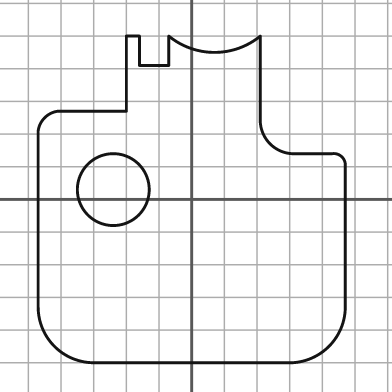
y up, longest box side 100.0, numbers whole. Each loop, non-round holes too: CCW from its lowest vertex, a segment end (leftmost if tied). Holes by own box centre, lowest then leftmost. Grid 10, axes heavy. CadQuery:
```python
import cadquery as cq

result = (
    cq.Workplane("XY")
    .moveTo(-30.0, -50.0)
    .lineTo(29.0, -50.0)
    .threePointArc((42.0, -45.0), (47.0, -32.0))
    .lineTo(47.0, 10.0)
    .threePointArc((46.0, 13.0), (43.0, 14.0))
    .lineTo(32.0, 14.0)
    .threePointArc((24.0, 17.0), (21.0, 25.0))
    .lineTo(21.0, 50.0)
    .threePointArc((7.0, 45.0), (-7.0, 50.0))
    .lineTo(-7.0, 41.0)
    .lineTo(-16.0, 41.0)
    .lineTo(-16.0, 50.0)
    .lineTo(-20.0, 50.0)
    .lineTo(-20.0, 27.0)
    .lineTo(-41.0, 27.0)
    .threePointArc((-45.0, 25.0), (-47.0, 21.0))
    .lineTo(-47.0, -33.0)
    .threePointArc((-42.0, -45.0), (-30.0, -50.0))
    .close()
    .moveTo(-24.0, 3.0)
    .circle(11.0)
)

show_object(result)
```